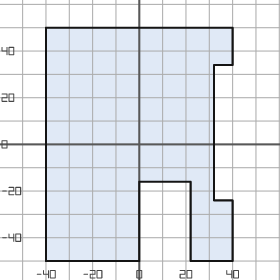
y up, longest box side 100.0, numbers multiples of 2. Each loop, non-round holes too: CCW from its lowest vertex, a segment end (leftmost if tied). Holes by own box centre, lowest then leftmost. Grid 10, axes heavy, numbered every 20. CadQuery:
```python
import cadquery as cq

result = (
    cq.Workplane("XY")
    .moveTo(-40.0, -50.0)
    .lineTo(0.0, -50.0)
    .lineTo(0.0, -16.0)
    .lineTo(22.0, -16.0)
    .lineTo(22.0, -50.0)
    .lineTo(40.0, -50.0)
    .lineTo(40.0, -24.0)
    .lineTo(32.0, -24.0)
    .lineTo(32.0, 34.0)
    .lineTo(40.0, 34.0)
    .lineTo(40.0, 50.0)
    .lineTo(-40.0, 50.0)
    .close()
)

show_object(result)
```